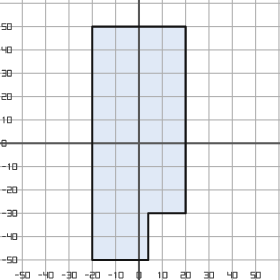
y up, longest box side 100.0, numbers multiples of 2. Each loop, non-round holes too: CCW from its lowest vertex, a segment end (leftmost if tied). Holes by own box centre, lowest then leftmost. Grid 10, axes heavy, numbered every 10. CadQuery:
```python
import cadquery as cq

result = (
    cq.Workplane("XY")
    .moveTo(-20.0, -50.0)
    .lineTo(4.0, -50.0)
    .lineTo(4.0, -30.0)
    .lineTo(20.0, -30.0)
    .lineTo(20.0, 50.0)
    .lineTo(-20.0, 50.0)
    .close()
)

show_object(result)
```